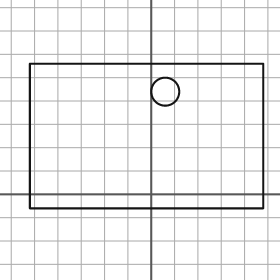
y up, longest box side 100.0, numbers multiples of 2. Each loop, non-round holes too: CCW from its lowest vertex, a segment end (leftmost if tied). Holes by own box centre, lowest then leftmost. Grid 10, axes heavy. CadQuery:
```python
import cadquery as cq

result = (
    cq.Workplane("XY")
    .moveTo(-52.0, -6.0)
    .lineTo(48.0, -6.0)
    .lineTo(48.0, 56.0)
    .lineTo(-52.0, 56.0)
    .close()
    .moveTo(6.0, 44.0)
    .circle(6.0)
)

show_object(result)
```